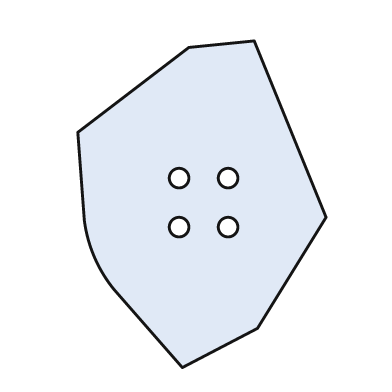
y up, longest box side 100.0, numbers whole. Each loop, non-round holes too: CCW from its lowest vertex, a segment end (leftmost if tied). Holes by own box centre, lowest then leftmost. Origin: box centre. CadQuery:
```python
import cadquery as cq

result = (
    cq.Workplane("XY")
    .moveTo(-6.0, -50.0)
    .lineTo(17.0, -38.0)
    .lineTo(38.0, -4.0)
    .lineTo(16.0, 50.0)
    .lineTo(-4.0, 48.0)
    .lineTo(-38.0, 22.0)
    .lineTo(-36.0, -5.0)
    .threePointArc((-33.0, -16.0), (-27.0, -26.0))
    .close()
    .moveTo(-7.0, -7.0)
    .circle(3.0)
    .moveTo(8.0, -7.0)
    .circle(3.0)
    .moveTo(-7.0, 8.0)
    .circle(3.0)
    .moveTo(8.0, 8.0)
    .circle(3.0)
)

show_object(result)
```